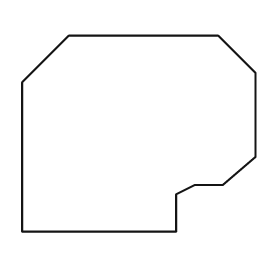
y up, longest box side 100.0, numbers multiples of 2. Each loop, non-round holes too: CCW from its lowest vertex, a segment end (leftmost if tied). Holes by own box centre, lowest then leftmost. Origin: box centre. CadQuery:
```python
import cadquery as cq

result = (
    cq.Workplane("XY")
    .moveTo(-50.0, -42.0)
    .lineTo(16.0, -42.0)
    .lineTo(16.0, -26.0)
    .lineTo(24.0, -22.0)
    .lineTo(36.0, -22.0)
    .lineTo(50.0, -10.0)
    .lineTo(50.0, 26.0)
    .lineTo(34.0, 42.0)
    .lineTo(-30.0, 42.0)
    .lineTo(-50.0, 22.0)
    .close()
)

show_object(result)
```